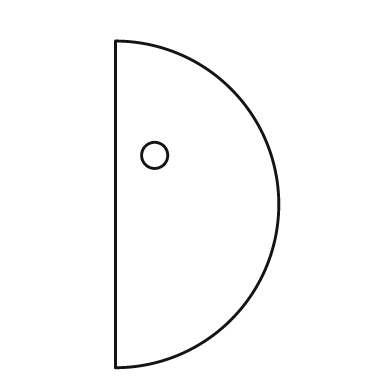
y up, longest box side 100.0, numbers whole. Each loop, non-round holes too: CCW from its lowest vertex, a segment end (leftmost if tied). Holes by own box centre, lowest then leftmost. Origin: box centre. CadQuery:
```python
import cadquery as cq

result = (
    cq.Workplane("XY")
    .moveTo(-25.0, -50.0)
    .threePointArc((25.0, 0.0), (-25.0, 50.0))
    .close()
    .moveTo(-13.0, 15.0)
    .circle(4.0)
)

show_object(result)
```